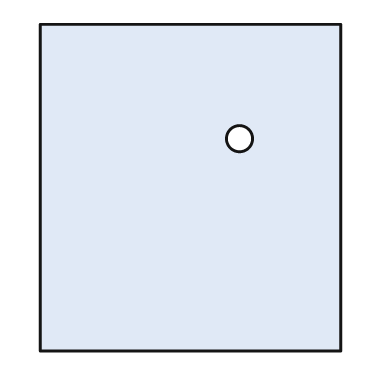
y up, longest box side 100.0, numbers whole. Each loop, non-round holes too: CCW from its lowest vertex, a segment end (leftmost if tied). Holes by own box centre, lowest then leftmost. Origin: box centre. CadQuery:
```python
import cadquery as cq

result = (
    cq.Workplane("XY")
    .moveTo(-46.0, -50.0)
    .lineTo(46.0, -50.0)
    .lineTo(46.0, 50.0)
    .lineTo(-46.0, 50.0)
    .close()
    .moveTo(15.0, 15.0)
    .circle(4.0)
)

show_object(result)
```